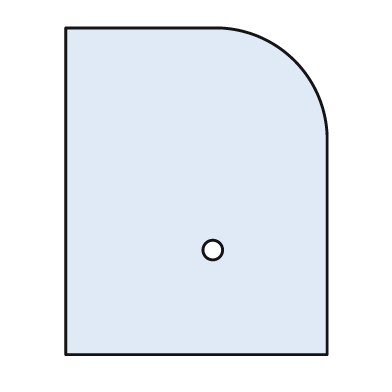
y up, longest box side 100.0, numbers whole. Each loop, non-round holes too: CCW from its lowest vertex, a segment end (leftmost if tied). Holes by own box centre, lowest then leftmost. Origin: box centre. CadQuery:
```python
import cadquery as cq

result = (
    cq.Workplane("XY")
    .moveTo(-40.0, -50.0)
    .lineTo(40.0, -50.0)
    .lineTo(40.0, 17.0)
    .threePointArc((30.0, 40.0), (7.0, 50.0))
    .lineTo(-40.0, 50.0)
    .close()
    .moveTo(5.0, -18.0)
    .circle(3.0)
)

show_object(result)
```